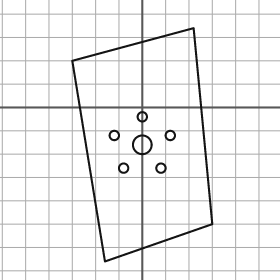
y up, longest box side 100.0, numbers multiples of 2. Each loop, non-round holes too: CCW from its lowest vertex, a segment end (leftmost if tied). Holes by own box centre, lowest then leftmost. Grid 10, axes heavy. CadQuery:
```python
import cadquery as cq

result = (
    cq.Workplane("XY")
    .moveTo(-16.0, -66.0)
    .lineTo(30.0, -50.0)
    .lineTo(22.0, 34.0)
    .lineTo(-30.0, 20.0)
    .close()
    .moveTo(-8.0, -26.0)
    .circle(2.0)
    .moveTo(8.0, -26.0)
    .circle(2.0)
    .moveTo(0.0, -16.0)
    .circle(4.0)
    .moveTo(-12.0, -12.0)
    .circle(2.0)
    .moveTo(12.0, -12.0)
    .circle(2.0)
    .moveTo(0.0, -4.0)
    .circle(2.0)
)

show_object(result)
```